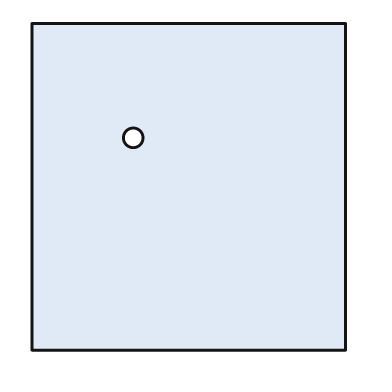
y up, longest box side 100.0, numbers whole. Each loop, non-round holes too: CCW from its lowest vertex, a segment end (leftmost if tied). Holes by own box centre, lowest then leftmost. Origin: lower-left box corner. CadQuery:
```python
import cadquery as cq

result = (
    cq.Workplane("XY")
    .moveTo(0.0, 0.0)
    .lineTo(96.0, 0.0)
    .lineTo(96.0, 100.0)
    .lineTo(0.0, 100.0)
    .close()
    .moveTo(31.0, 65.0)
    .circle(3.0)
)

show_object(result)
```